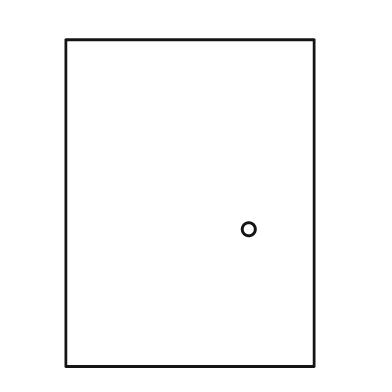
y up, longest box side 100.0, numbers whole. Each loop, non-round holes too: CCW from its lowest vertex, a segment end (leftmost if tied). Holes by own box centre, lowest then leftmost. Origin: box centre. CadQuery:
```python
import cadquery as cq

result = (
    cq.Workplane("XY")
    .moveTo(-38.0, -50.0)
    .lineTo(38.0, -50.0)
    .lineTo(38.0, 50.0)
    .lineTo(-38.0, 50.0)
    .close()
    .moveTo(18.0, -8.0)
    .circle(2.0)
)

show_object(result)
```